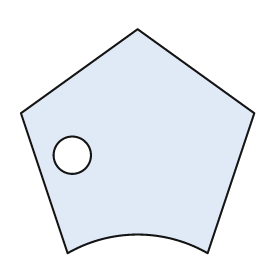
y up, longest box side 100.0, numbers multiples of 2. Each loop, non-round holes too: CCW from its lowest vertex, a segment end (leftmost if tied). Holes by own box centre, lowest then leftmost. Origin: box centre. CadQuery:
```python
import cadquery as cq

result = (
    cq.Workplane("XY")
    .moveTo(-30.0, -48.0)
    .threePointArc((0.0, -40.0), (30.0, -48.0))
    .lineTo(50.0, 12.0)
    .lineTo(0.0, 48.0)
    .lineTo(-50.0, 12.0)
    .close()
    .moveTo(-28.0, -6.0)
    .circle(8.0)
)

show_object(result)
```